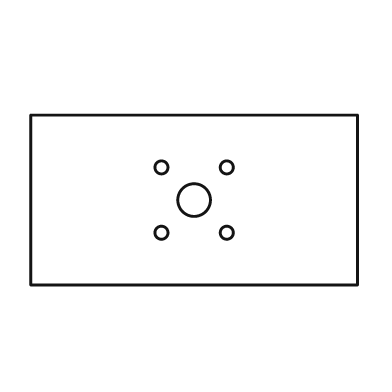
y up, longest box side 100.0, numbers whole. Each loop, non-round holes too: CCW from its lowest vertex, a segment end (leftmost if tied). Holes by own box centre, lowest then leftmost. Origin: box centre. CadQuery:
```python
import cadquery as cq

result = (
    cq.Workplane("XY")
    .moveTo(-50.0, -26.0)
    .lineTo(50.0, -26.0)
    .lineTo(50.0, 26.0)
    .lineTo(-50.0, 26.0)
    .close()
    .moveTo(-10.0, -10.0)
    .circle(2.0)
    .moveTo(10.0, -10.0)
    .circle(2.0)
    .moveTo(0.0, 0.0)
    .circle(5.0)
    .moveTo(-10.0, 10.0)
    .circle(2.0)
    .moveTo(10.0, 10.0)
    .circle(2.0)
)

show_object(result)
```